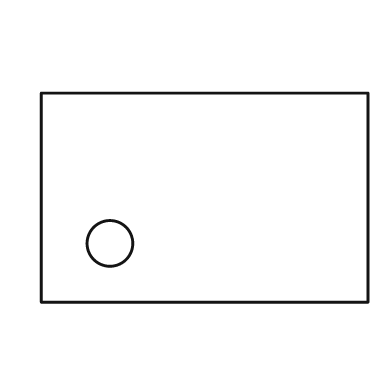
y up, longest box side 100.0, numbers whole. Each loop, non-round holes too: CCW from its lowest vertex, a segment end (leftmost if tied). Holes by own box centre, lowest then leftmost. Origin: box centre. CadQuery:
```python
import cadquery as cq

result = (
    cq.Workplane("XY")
    .moveTo(-50.0, -32.0)
    .lineTo(50.0, -32.0)
    .lineTo(50.0, 32.0)
    .lineTo(-50.0, 32.0)
    .close()
    .moveTo(-29.0, -14.0)
    .circle(7.0)
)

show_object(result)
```